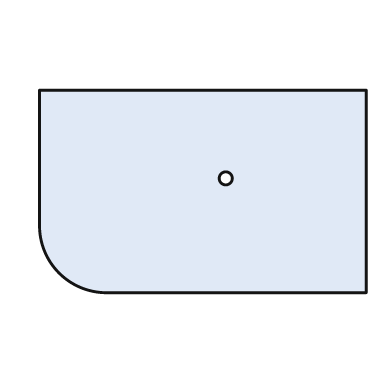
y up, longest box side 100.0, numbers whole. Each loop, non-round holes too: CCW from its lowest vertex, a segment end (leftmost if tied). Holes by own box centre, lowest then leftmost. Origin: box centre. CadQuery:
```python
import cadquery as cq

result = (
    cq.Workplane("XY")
    .moveTo(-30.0, -31.0)
    .lineTo(50.0, -31.0)
    .lineTo(50.0, 31.0)
    .lineTo(-50.0, 31.0)
    .lineTo(-50.0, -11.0)
    .threePointArc((-44.0, -25.0), (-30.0, -31.0))
    .close()
    .moveTo(7.0, 4.0)
    .circle(2.0)
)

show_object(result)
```